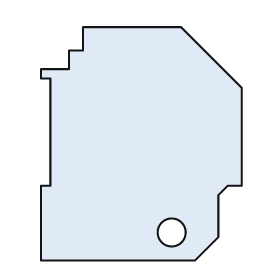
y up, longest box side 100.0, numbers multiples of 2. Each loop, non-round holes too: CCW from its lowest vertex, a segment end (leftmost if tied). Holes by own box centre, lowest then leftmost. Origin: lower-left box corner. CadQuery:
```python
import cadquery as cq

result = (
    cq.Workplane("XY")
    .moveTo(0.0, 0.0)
    .lineTo(66.0, 0.0)
    .lineTo(76.0, 10.0)
    .lineTo(76.0, 28.0)
    .lineTo(80.0, 32.0)
    .lineTo(86.0, 32.0)
    .lineTo(86.0, 74.0)
    .lineTo(60.0, 100.0)
    .lineTo(18.0, 100.0)
    .lineTo(18.0, 90.0)
    .lineTo(12.0, 90.0)
    .lineTo(12.0, 82.0)
    .lineTo(0.0, 82.0)
    .lineTo(0.0, 78.0)
    .lineTo(4.0, 78.0)
    .lineTo(4.0, 32.0)
    .lineTo(0.0, 32.0)
    .close()
    .moveTo(56.0, 12.0)
    .circle(6.0)
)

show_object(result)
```